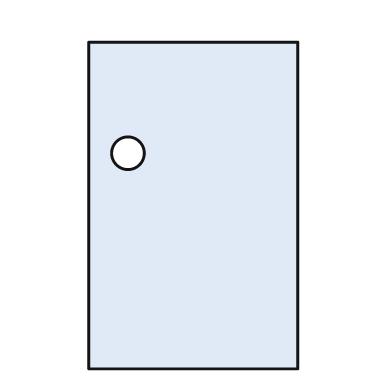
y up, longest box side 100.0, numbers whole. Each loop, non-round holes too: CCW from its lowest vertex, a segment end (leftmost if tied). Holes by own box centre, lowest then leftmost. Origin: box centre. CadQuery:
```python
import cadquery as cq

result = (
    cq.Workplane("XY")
    .moveTo(-32.0, -50.0)
    .lineTo(32.0, -50.0)
    .lineTo(32.0, 50.0)
    .lineTo(-32.0, 50.0)
    .close()
    .moveTo(-20.0, 16.0)
    .circle(5.0)
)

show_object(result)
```